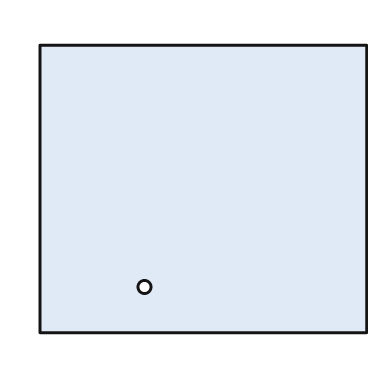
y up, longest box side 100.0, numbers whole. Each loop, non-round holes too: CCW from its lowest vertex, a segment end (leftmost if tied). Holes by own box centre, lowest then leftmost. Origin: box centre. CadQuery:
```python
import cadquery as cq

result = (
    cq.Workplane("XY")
    .moveTo(-50.0, -44.0)
    .lineTo(50.0, -44.0)
    .lineTo(50.0, 44.0)
    .lineTo(-50.0, 44.0)
    .close()
    .moveTo(-18.0, -30.0)
    .circle(2.0)
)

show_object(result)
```